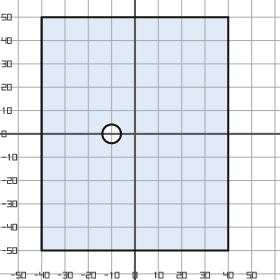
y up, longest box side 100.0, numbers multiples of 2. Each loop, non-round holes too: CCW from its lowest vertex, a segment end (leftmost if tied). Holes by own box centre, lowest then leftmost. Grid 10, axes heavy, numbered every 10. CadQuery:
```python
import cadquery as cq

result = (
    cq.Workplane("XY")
    .moveTo(-40.0, -50.0)
    .lineTo(40.0, -50.0)
    .lineTo(40.0, 50.0)
    .lineTo(-40.0, 50.0)
    .close()
    .moveTo(-10.0, 0.0)
    .circle(4.0)
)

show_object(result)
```